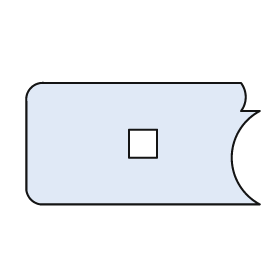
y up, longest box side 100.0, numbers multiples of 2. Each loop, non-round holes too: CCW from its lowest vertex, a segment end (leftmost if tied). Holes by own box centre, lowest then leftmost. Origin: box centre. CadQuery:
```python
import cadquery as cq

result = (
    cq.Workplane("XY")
    .moveTo(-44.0, -26.0)
    .lineTo(50.0, -26.0)
    .threePointArc((38.0, -6.0), (50.0, 14.0))
    .lineTo(42.0, 14.0)
    .threePointArc((44.0, 20.0), (42.0, 26.0))
    .lineTo(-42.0, 26.0)
    .threePointArc((-48.0, 24.0), (-50.0, 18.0))
    .lineTo(-50.0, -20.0)
    .threePointArc((-48.0, -24.0), (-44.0, -26.0))
    .close()
    .moveTo(-6.0, -6.0)
    .lineTo(6.0, -6.0)
    .lineTo(6.0, 6.0)
    .lineTo(-6.0, 6.0)
    .close()
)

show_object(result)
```